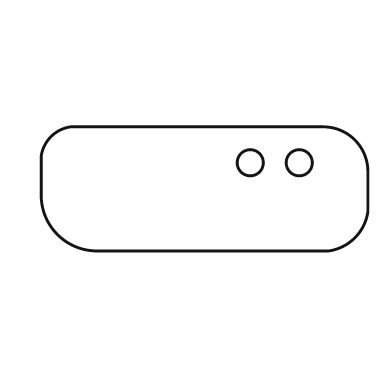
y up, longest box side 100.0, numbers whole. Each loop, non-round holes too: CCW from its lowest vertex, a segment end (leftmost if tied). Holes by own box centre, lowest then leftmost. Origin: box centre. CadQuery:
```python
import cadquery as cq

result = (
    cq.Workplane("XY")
    .moveTo(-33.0, -19.0)
    .lineTo(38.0, -19.0)
    .threePointArc((46.0, -15.0), (50.0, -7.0))
    .lineTo(50.0, 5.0)
    .threePointArc((46.0, 15.0), (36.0, 19.0))
    .lineTo(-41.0, 19.0)
    .threePointArc((-47.0, 16.0), (-50.0, 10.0))
    .lineTo(-50.0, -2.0)
    .threePointArc((-45.0, -14.0), (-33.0, -19.0))
    .close()
    .moveTo(14.0, 8.0)
    .circle(4.0)
    .moveTo(29.0, 8.0)
    .circle(4.0)
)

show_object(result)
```